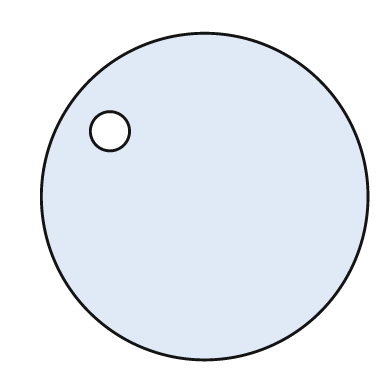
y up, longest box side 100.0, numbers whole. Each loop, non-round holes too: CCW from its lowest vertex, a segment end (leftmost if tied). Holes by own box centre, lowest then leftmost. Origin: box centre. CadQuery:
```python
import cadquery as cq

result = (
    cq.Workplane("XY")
    .moveTo(0.0, 0.0)
    .circle(50.0)
    .moveTo(-29.0, 20.0)
    .circle(6.0)
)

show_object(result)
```